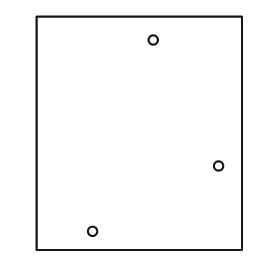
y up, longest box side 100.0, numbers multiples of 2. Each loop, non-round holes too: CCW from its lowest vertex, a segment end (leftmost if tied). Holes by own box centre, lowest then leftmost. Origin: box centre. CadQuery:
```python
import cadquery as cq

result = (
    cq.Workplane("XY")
    .moveTo(-44.0, -50.0)
    .lineTo(44.0, -50.0)
    .lineTo(44.0, 50.0)
    .lineTo(-44.0, 50.0)
    .close()
    .moveTo(-20.0, -42.0)
    .circle(2.0)
    .moveTo(34.0, -14.0)
    .circle(2.0)
    .moveTo(6.0, 40.0)
    .circle(2.0)
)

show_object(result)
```